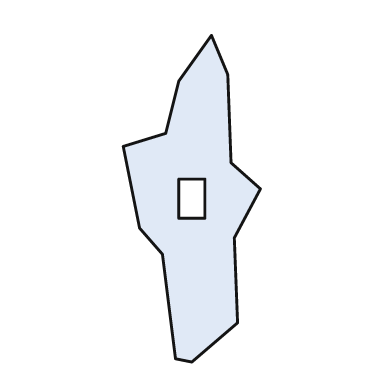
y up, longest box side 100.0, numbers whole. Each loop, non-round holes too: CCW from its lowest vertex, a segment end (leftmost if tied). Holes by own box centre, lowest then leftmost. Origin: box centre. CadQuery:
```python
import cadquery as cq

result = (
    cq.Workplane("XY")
    .moveTo(0.0, -50.0)
    .lineTo(14.0, -38.0)
    .lineTo(13.0, -12.0)
    .lineTo(21.0, 3.0)
    .lineTo(12.0, 11.0)
    .lineTo(11.0, 38.0)
    .lineTo(6.0, 50.0)
    .lineTo(-4.0, 36.0)
    .lineTo(-8.0, 20.0)
    .lineTo(-21.0, 16.0)
    .lineTo(-16.0, -9.0)
    .lineTo(-9.0, -17.0)
    .lineTo(-5.0, -49.0)
    .close()
    .moveTo(-4.0, -6.0)
    .lineTo(4.0, -6.0)
    .lineTo(4.0, 6.0)
    .lineTo(-4.0, 6.0)
    .close()
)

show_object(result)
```